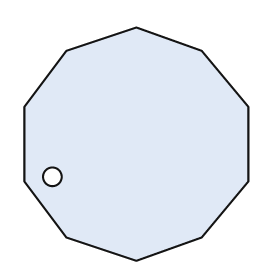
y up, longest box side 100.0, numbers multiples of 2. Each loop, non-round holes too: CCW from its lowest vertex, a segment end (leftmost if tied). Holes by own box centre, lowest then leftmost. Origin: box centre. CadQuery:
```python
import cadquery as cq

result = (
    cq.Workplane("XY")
    .moveTo(0.0, -50.0)
    .lineTo(28.0, -40.0)
    .lineTo(48.0, -16.0)
    .lineTo(48.0, 16.0)
    .lineTo(28.0, 40.0)
    .lineTo(0.0, 50.0)
    .lineTo(-30.0, 40.0)
    .lineTo(-48.0, 16.0)
    .lineTo(-48.0, -16.0)
    .lineTo(-30.0, -40.0)
    .close()
    .moveTo(-36.0, -14.0)
    .circle(4.0)
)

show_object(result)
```